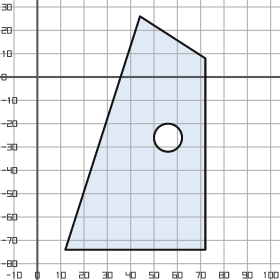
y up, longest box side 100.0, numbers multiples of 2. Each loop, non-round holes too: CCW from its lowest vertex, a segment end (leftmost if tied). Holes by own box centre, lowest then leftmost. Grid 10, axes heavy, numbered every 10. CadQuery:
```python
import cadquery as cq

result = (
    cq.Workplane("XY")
    .moveTo(12.0, -74.0)
    .lineTo(72.0, -74.0)
    .lineTo(72.0, 8.0)
    .lineTo(44.0, 26.0)
    .close()
    .moveTo(56.0, -26.0)
    .circle(6.0)
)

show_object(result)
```